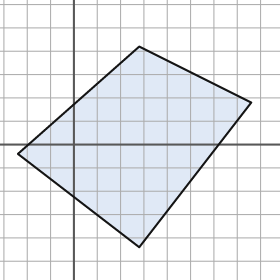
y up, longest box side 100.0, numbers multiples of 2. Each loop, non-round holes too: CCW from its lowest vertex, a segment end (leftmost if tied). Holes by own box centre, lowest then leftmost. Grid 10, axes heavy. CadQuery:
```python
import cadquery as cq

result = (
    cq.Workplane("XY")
    .moveTo(28.0, -44.0)
    .lineTo(76.0, 18.0)
    .lineTo(28.0, 42.0)
    .lineTo(-24.0, -4.0)
    .close()
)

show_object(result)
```